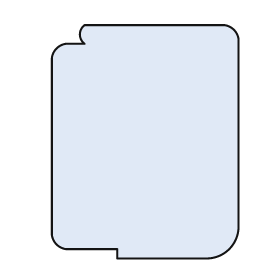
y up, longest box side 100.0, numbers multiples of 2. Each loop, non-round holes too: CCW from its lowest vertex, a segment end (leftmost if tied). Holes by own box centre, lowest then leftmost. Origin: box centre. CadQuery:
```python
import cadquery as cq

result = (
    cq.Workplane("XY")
    .moveTo(-12.0, -50.0)
    .lineTo(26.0, -50.0)
    .threePointArc((36.0, -46.0), (40.0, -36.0))
    .lineTo(40.0, 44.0)
    .threePointArc((38.0, 48.0), (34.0, 50.0))
    .lineTo(-26.0, 50.0)
    .threePointArc((-28.0, 46.0), (-26.0, 42.0))
    .lineTo(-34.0, 42.0)
    .threePointArc((-38.0, 40.0), (-40.0, 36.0))
    .lineTo(-40.0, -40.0)
    .threePointArc((-38.0, -44.0), (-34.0, -46.0))
    .lineTo(-12.0, -46.0)
    .close()
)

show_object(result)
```